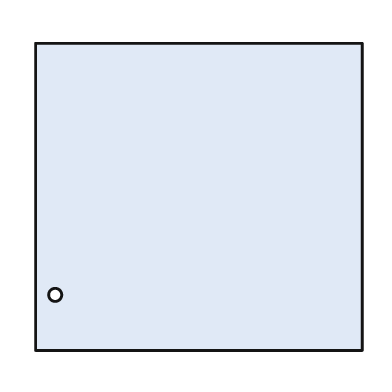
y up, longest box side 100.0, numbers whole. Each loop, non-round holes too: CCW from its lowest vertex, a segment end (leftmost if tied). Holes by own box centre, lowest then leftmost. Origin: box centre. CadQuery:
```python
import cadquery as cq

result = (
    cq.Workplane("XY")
    .moveTo(-50.0, -47.0)
    .lineTo(50.0, -47.0)
    .lineTo(50.0, 47.0)
    .lineTo(-50.0, 47.0)
    .close()
    .moveTo(-44.0, -30.0)
    .circle(2.0)
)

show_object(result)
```